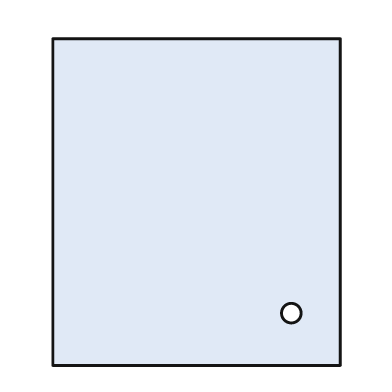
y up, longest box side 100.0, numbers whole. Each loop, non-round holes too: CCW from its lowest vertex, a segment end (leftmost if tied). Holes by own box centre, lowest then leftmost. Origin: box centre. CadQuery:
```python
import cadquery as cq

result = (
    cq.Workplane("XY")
    .moveTo(-44.0, -50.0)
    .lineTo(44.0, -50.0)
    .lineTo(44.0, 50.0)
    .lineTo(-44.0, 50.0)
    .close()
    .moveTo(29.0, -34.0)
    .circle(3.0)
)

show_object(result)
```